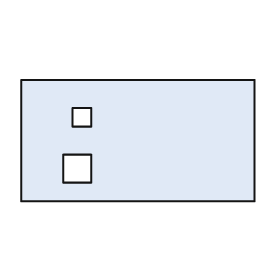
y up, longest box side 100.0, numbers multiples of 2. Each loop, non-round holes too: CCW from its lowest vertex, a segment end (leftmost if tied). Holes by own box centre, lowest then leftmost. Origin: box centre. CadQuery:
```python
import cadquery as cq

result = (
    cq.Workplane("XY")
    .moveTo(-50.0, -26.0)
    .lineTo(50.0, -26.0)
    .lineTo(50.0, 26.0)
    .lineTo(-50.0, 26.0)
    .close()
    .moveTo(-32.0, -18.0)
    .lineTo(-20.0, -18.0)
    .lineTo(-20.0, -6.0)
    .lineTo(-32.0, -6.0)
    .close()
    .moveTo(-28.0, 6.0)
    .lineTo(-20.0, 6.0)
    .lineTo(-20.0, 14.0)
    .lineTo(-28.0, 14.0)
    .close()
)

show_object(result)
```